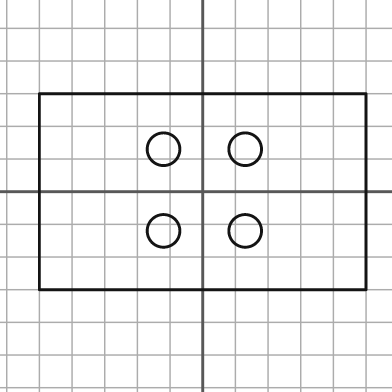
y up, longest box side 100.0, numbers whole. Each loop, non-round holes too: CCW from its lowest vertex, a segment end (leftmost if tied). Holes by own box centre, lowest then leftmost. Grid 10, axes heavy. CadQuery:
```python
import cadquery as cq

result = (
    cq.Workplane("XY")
    .moveTo(-50.0, -30.0)
    .lineTo(50.0, -30.0)
    .lineTo(50.0, 30.0)
    .lineTo(-50.0, 30.0)
    .close()
    .moveTo(-12.0, -12.0)
    .circle(5.0)
    .moveTo(13.0, -12.0)
    .circle(5.0)
    .moveTo(-12.0, 13.0)
    .circle(5.0)
    .moveTo(13.0, 13.0)
    .circle(5.0)
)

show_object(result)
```